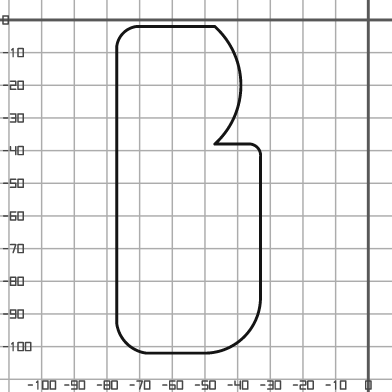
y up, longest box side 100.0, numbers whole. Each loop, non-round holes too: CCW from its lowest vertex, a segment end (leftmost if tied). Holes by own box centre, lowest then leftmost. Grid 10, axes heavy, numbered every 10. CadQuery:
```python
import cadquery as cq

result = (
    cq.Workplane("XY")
    .moveTo(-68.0, -102.0)
    .lineTo(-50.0, -102.0)
    .threePointArc((-38.0, -97.0), (-33.0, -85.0))
    .lineTo(-33.0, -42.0)
    .threePointArc((-34.0, -39.0), (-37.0, -38.0))
    .lineTo(-47.0, -38.0)
    .threePointArc((-39.0, -20.0), (-47.0, -2.0))
    .lineTo(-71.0, -2.0)
    .threePointArc((-75.0, -4.0), (-77.0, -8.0))
    .lineTo(-77.0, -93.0)
    .threePointArc((-74.0, -99.0), (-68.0, -102.0))
    .close()
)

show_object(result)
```